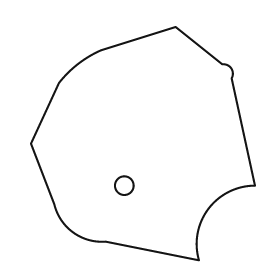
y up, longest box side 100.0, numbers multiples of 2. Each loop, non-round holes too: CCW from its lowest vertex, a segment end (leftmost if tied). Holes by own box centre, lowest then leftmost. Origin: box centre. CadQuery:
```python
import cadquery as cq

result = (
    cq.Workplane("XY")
    .moveTo(24.0, -50.0)
    .threePointArc((28.0, -28.0), (48.0, -18.0))
    .lineTo(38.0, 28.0)
    .threePointArc((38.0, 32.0), (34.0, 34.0))
    .lineTo(14.0, 50.0)
    .lineTo(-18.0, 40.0)
    .threePointArc((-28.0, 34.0), (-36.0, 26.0))
    .lineTo(-48.0, 0.0)
    .lineTo(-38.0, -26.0)
    .threePointArc((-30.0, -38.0), (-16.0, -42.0))
    .close()
    .moveTo(-8.0, -18.0)
    .circle(4.0)
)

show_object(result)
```